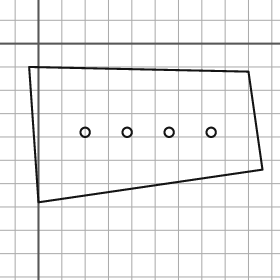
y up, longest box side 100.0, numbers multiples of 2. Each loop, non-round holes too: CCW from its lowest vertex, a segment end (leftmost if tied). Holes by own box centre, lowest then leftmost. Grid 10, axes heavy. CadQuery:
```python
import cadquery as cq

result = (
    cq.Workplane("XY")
    .moveTo(0.0, -68.0)
    .lineTo(96.0, -54.0)
    .lineTo(90.0, -12.0)
    .lineTo(-4.0, -10.0)
    .close()
    .moveTo(20.0, -38.0)
    .circle(2.0)
    .moveTo(38.0, -38.0)
    .circle(2.0)
    .moveTo(56.0, -38.0)
    .circle(2.0)
    .moveTo(74.0, -38.0)
    .circle(2.0)
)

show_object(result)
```